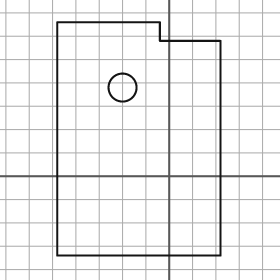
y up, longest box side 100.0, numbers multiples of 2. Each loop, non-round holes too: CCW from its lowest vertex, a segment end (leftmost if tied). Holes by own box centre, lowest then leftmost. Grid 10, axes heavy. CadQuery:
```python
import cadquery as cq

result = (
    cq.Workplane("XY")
    .moveTo(-48.0, -34.0)
    .lineTo(22.0, -34.0)
    .lineTo(22.0, 58.0)
    .lineTo(-4.0, 58.0)
    .lineTo(-4.0, 66.0)
    .lineTo(-48.0, 66.0)
    .close()
    .moveTo(-20.0, 38.0)
    .circle(6.0)
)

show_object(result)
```